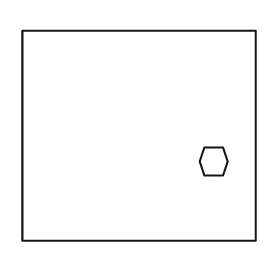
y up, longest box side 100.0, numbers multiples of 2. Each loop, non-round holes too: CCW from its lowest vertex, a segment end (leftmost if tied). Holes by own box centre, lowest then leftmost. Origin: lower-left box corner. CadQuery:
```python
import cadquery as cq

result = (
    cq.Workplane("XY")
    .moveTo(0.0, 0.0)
    .lineTo(100.0, 0.0)
    .lineTo(100.0, 90.0)
    .lineTo(0.0, 90.0)
    .close()
    .moveTo(78.0, 28.0)
    .lineTo(86.0, 28.0)
    .lineTo(88.0, 34.0)
    .lineTo(86.0, 40.0)
    .lineTo(78.0, 40.0)
    .lineTo(76.0, 34.0)
    .close()
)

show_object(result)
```